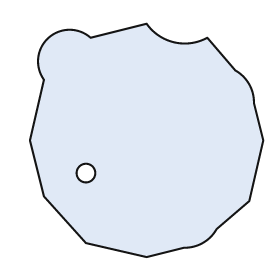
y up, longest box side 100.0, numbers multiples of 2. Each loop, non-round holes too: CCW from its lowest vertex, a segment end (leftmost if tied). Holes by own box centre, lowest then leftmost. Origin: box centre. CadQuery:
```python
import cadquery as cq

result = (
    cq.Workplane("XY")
    .moveTo(0.0, -50.0)
    .lineTo(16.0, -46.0)
    .threePointArc((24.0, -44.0), (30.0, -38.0))
    .lineTo(44.0, -26.0)
    .lineTo(50.0, 0.0)
    .lineTo(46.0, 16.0)
    .threePointArc((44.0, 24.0), (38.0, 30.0))
    .lineTo(26.0, 44.0)
    .threePointArc((12.0, 42.0), (0.0, 50.0))
    .lineTo(-24.0, 44.0)
    .threePointArc((-42.0, 44.0), (-44.0, 26.0))
    .lineTo(-50.0, 0.0)
    .lineTo(-44.0, -24.0)
    .lineTo(-26.0, -44.0)
    .close()
    .moveTo(-26.0, -14.0)
    .circle(4.0)
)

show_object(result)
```